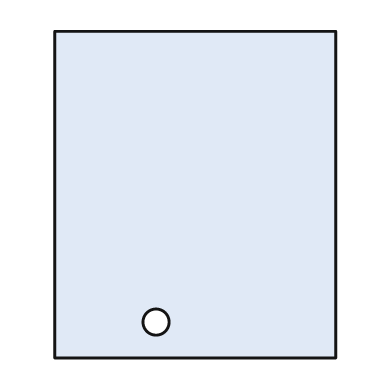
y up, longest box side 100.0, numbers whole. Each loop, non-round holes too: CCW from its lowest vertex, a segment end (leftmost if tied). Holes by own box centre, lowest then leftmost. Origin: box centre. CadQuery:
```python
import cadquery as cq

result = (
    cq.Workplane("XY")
    .moveTo(-43.0, -50.0)
    .lineTo(43.0, -50.0)
    .lineTo(43.0, 50.0)
    .lineTo(-43.0, 50.0)
    .close()
    .moveTo(-12.0, -39.0)
    .circle(4.0)
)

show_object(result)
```